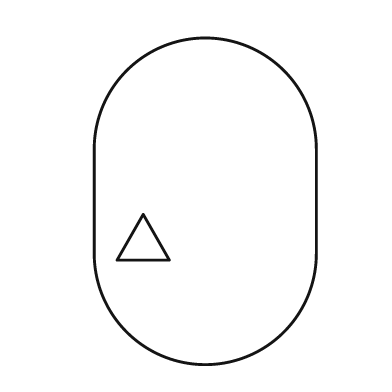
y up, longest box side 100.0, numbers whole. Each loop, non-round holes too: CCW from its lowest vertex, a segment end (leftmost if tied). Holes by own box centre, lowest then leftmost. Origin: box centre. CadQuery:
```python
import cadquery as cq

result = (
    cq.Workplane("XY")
    .moveTo(-34.0, -16.0)
    .threePointArc((0.0, -50.0), (34.0, -16.0))
    .lineTo(34.0, 16.0)
    .threePointArc((0.0, 50.0), (-34.0, 16.0))
    .close()
    .moveTo(-27.0, -18.0)
    .lineTo(-11.0, -18.0)
    .lineTo(-19.0, -4.0)
    .close()
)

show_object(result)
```